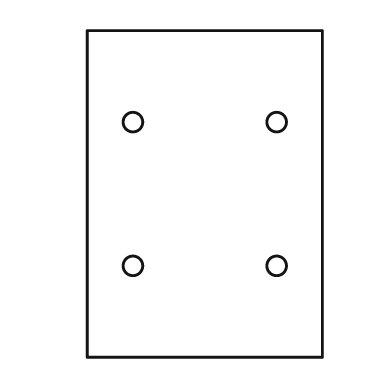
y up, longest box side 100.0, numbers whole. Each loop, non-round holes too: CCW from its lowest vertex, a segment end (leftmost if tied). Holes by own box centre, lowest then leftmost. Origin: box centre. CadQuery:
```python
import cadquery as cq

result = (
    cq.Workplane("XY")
    .moveTo(-36.0, -50.0)
    .lineTo(36.0, -50.0)
    .lineTo(36.0, 50.0)
    .lineTo(-36.0, 50.0)
    .close()
    .moveTo(-22.0, -22.0)
    .circle(3.0)
    .moveTo(22.0, -22.0)
    .circle(3.0)
    .moveTo(-22.0, 22.0)
    .circle(3.0)
    .moveTo(22.0, 22.0)
    .circle(3.0)
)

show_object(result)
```